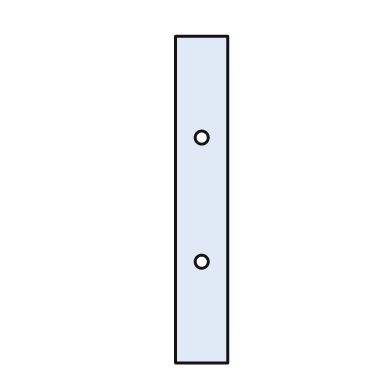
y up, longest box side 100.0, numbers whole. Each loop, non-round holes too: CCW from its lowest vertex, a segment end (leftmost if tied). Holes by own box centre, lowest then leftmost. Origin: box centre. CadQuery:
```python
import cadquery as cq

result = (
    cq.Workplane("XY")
    .moveTo(-8.0, -50.0)
    .lineTo(8.0, -50.0)
    .lineTo(8.0, 50.0)
    .lineTo(-8.0, 50.0)
    .close()
    .moveTo(0.0, -19.0)
    .circle(2.0)
    .moveTo(0.0, 19.0)
    .circle(2.0)
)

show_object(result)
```